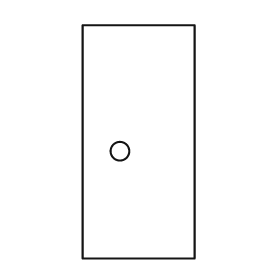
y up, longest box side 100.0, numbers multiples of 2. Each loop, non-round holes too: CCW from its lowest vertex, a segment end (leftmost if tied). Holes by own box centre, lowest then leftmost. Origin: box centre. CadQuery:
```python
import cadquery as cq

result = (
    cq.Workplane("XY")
    .moveTo(-24.0, -50.0)
    .lineTo(24.0, -50.0)
    .lineTo(24.0, 50.0)
    .lineTo(-24.0, 50.0)
    .close()
    .moveTo(-8.0, -4.0)
    .circle(4.0)
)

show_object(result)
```